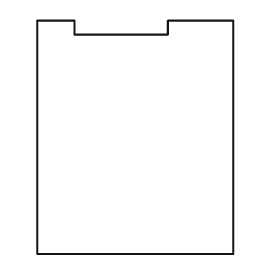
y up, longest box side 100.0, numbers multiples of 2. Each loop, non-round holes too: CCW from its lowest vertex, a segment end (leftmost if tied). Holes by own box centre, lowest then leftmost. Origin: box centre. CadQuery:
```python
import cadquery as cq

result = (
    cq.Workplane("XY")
    .moveTo(-42.0, -50.0)
    .lineTo(42.0, -50.0)
    .lineTo(42.0, 50.0)
    .lineTo(14.0, 50.0)
    .lineTo(14.0, 44.0)
    .lineTo(-26.0, 44.0)
    .lineTo(-26.0, 50.0)
    .lineTo(-42.0, 50.0)
    .close()
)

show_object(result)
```